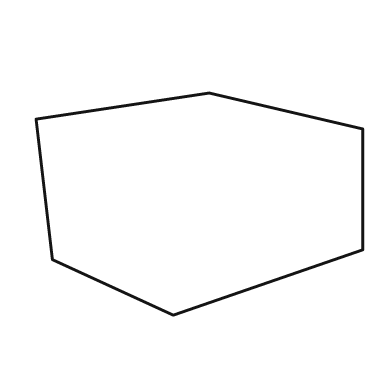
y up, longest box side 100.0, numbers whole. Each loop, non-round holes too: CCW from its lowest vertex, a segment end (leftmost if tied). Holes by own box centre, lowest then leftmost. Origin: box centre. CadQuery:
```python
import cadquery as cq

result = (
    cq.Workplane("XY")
    .moveTo(-8.0, -34.0)
    .lineTo(50.0, -14.0)
    .lineTo(50.0, 23.0)
    .lineTo(3.0, 34.0)
    .lineTo(-50.0, 26.0)
    .lineTo(-45.0, -17.0)
    .close()
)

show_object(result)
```